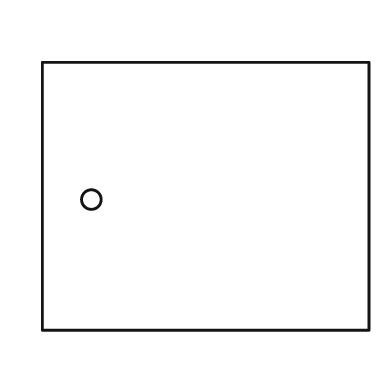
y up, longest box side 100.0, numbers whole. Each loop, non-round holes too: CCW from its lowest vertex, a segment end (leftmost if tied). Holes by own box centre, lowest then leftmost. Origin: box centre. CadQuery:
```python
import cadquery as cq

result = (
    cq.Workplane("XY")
    .moveTo(-50.0, -41.0)
    .lineTo(50.0, -41.0)
    .lineTo(50.0, 41.0)
    .lineTo(-50.0, 41.0)
    .close()
    .moveTo(-35.0, -1.0)
    .circle(3.0)
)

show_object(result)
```